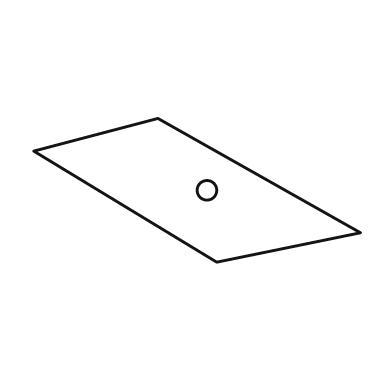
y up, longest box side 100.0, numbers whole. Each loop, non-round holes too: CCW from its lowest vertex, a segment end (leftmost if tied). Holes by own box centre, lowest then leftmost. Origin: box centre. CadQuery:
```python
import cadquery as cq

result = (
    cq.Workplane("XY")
    .moveTo(6.0, -22.0)
    .lineTo(50.0, -13.0)
    .lineTo(-12.0, 22.0)
    .lineTo(-50.0, 12.0)
    .close()
    .moveTo(3.0, 0.0)
    .circle(3.0)
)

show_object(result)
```